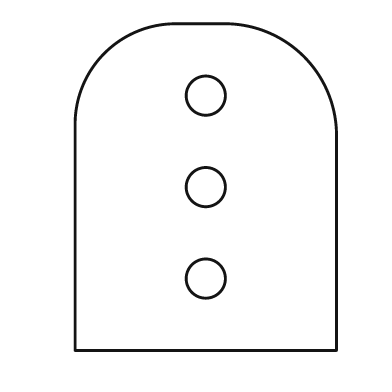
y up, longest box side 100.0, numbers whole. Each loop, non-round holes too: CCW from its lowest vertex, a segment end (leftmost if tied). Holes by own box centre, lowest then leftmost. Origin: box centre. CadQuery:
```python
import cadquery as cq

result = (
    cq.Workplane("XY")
    .moveTo(-40.0, -50.0)
    .lineTo(40.0, -50.0)
    .lineTo(40.0, 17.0)
    .threePointArc((30.0, 40.0), (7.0, 50.0))
    .lineTo(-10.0, 50.0)
    .threePointArc((-31.0, 41.0), (-40.0, 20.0))
    .close()
    .moveTo(0.0, -28.0)
    .circle(6.0)
    .moveTo(0.0, 0.0)
    .circle(6.0)
    .moveTo(0.0, 28.0)
    .circle(6.0)
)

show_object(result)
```